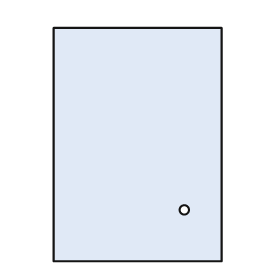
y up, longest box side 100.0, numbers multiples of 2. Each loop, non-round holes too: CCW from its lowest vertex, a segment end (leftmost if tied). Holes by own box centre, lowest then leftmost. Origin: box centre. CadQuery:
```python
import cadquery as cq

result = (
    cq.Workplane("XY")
    .moveTo(-36.0, -50.0)
    .lineTo(36.0, -50.0)
    .lineTo(36.0, 50.0)
    .lineTo(-36.0, 50.0)
    .close()
    .moveTo(20.0, -28.0)
    .circle(2.0)
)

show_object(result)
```